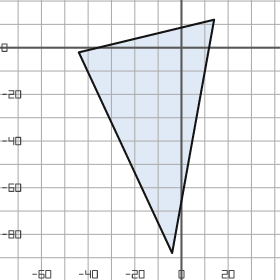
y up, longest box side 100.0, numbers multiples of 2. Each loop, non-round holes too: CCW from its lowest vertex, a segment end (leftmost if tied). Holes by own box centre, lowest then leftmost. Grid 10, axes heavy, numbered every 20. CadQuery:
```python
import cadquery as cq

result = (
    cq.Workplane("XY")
    .moveTo(-4.0, -88.0)
    .lineTo(14.0, 12.0)
    .lineTo(-44.0, -2.0)
    .close()
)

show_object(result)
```